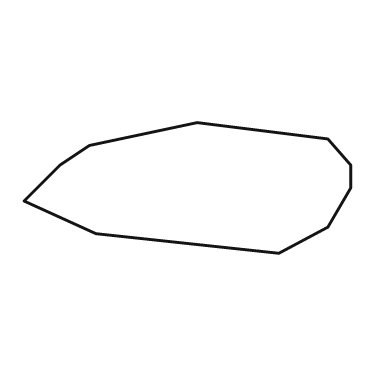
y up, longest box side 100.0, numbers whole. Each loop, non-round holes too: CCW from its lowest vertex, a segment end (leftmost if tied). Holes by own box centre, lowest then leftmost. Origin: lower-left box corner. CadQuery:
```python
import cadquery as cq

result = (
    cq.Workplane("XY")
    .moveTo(78.0, 0.0)
    .lineTo(93.0, 8.0)
    .lineTo(100.0, 20.0)
    .lineTo(100.0, 27.0)
    .lineTo(93.0, 35.0)
    .lineTo(53.0, 40.0)
    .lineTo(20.0, 33.0)
    .lineTo(11.0, 27.0)
    .lineTo(0.0, 16.0)
    .lineTo(22.0, 6.0)
    .close()
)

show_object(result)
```